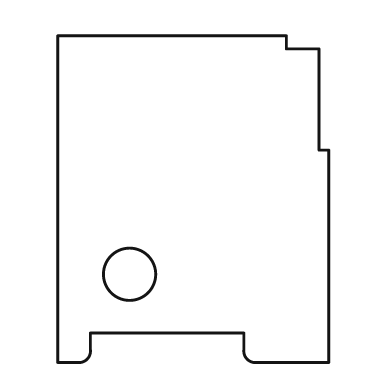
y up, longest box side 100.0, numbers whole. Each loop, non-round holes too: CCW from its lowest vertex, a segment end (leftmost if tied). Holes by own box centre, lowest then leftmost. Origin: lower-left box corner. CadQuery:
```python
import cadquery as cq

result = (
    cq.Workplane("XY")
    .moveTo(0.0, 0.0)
    .lineTo(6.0, 0.0)
    .threePointArc((9.0, 1.0), (10.0, 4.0))
    .lineTo(10.0, 9.0)
    .lineTo(57.0, 9.0)
    .lineTo(57.0, 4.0)
    .threePointArc((58.0, 1.0), (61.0, 0.0))
    .lineTo(83.0, 0.0)
    .lineTo(83.0, 65.0)
    .lineTo(80.0, 65.0)
    .lineTo(80.0, 96.0)
    .lineTo(70.0, 96.0)
    .lineTo(70.0, 100.0)
    .lineTo(0.0, 100.0)
    .close()
    .moveTo(22.0, 27.0)
    .circle(8.0)
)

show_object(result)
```